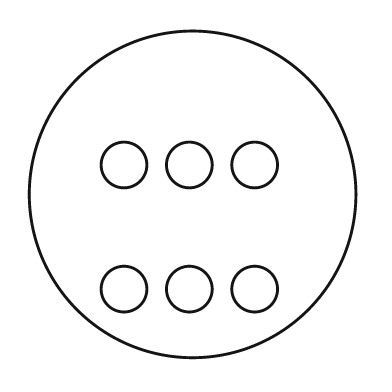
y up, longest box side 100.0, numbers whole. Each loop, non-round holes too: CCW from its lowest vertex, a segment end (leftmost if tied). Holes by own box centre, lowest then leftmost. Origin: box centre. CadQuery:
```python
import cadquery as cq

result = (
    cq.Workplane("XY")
    .moveTo(0.0, 0.0)
    .circle(50.0)
    .moveTo(-21.0, -29.0)
    .circle(7.0)
    .moveTo(-1.0, -29.0)
    .circle(7.0)
    .moveTo(19.0, -29.0)
    .circle(7.0)
    .moveTo(-21.0, 9.0)
    .circle(7.0)
    .moveTo(-1.0, 9.0)
    .circle(7.0)
    .moveTo(19.0, 9.0)
    .circle(7.0)
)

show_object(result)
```